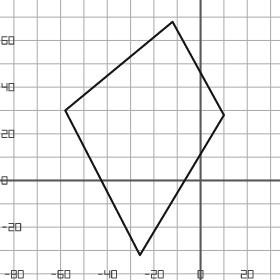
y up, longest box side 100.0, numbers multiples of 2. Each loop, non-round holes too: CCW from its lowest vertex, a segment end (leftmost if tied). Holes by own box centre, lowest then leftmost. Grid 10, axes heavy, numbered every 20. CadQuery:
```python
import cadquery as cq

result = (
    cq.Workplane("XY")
    .moveTo(-26.0, -32.0)
    .lineTo(10.0, 28.0)
    .lineTo(-12.0, 68.0)
    .lineTo(-58.0, 30.0)
    .close()
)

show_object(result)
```